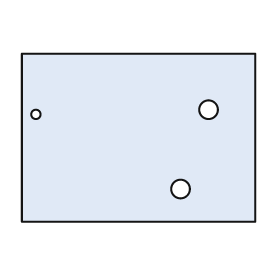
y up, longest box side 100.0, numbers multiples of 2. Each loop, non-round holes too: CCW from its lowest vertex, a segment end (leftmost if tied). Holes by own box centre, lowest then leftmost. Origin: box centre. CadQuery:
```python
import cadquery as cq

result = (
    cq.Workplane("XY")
    .moveTo(-50.0, -36.0)
    .lineTo(50.0, -36.0)
    .lineTo(50.0, 36.0)
    .lineTo(-50.0, 36.0)
    .close()
    .moveTo(18.0, -22.0)
    .circle(4.0)
    .moveTo(-44.0, 10.0)
    .circle(2.0)
    .moveTo(30.0, 12.0)
    .circle(4.0)
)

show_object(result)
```